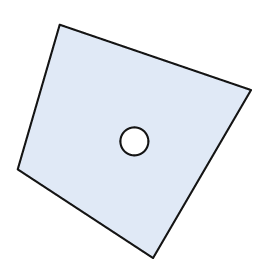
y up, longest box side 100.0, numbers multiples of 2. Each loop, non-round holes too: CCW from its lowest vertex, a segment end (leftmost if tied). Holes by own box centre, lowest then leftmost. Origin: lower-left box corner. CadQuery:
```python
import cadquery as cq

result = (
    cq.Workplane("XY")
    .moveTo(58.0, 0.0)
    .lineTo(100.0, 72.0)
    .lineTo(18.0, 100.0)
    .lineTo(0.0, 38.0)
    .close()
    .moveTo(50.0, 50.0)
    .circle(6.0)
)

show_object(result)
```